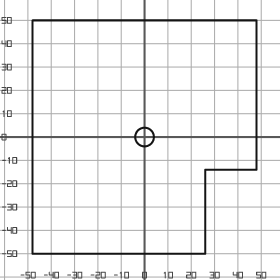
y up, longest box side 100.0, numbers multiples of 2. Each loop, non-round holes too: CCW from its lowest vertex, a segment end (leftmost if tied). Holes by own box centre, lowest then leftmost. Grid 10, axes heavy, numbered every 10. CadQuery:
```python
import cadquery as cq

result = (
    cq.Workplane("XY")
    .moveTo(-48.0, -50.0)
    .lineTo(26.0, -50.0)
    .lineTo(26.0, -14.0)
    .lineTo(48.0, -14.0)
    .lineTo(48.0, 50.0)
    .lineTo(-48.0, 50.0)
    .close()
    .moveTo(0.0, 0.0)
    .circle(4.0)
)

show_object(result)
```